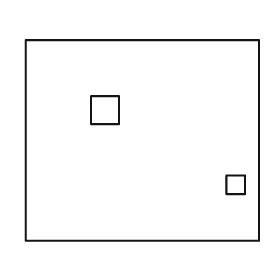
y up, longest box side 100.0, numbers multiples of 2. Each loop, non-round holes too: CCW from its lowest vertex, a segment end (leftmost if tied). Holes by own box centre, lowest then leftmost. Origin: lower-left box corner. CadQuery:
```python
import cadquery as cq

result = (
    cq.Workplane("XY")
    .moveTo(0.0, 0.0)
    .lineTo(100.0, 0.0)
    .lineTo(100.0, 86.0)
    .lineTo(0.0, 86.0)
    .close()
    .moveTo(86.0, 20.0)
    .lineTo(94.0, 20.0)
    .lineTo(94.0, 28.0)
    .lineTo(86.0, 28.0)
    .close()
    .moveTo(28.0, 50.0)
    .lineTo(40.0, 50.0)
    .lineTo(40.0, 62.0)
    .lineTo(28.0, 62.0)
    .close()
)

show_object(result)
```